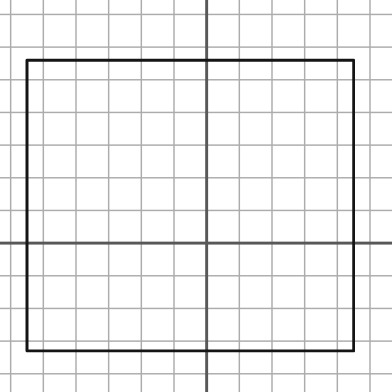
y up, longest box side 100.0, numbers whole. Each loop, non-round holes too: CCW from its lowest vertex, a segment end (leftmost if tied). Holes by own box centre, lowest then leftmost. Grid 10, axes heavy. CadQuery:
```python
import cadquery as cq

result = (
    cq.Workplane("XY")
    .moveTo(-55.0, -33.0)
    .lineTo(45.0, -33.0)
    .lineTo(45.0, 56.0)
    .lineTo(-55.0, 56.0)
    .close()
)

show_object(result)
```